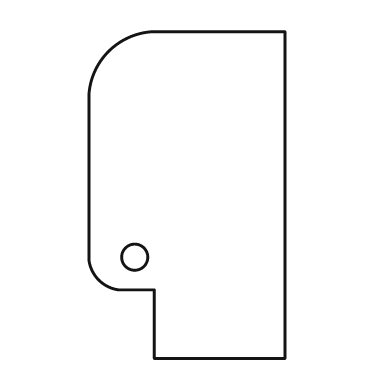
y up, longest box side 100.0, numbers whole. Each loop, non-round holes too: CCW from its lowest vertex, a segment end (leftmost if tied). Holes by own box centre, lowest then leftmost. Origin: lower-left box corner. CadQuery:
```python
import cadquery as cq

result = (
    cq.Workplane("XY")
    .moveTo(20.0, 0.0)
    .lineTo(60.0, 0.0)
    .lineTo(60.0, 100.0)
    .lineTo(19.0, 100.0)
    .threePointArc((6.0, 94.0), (0.0, 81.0))
    .lineTo(0.0, 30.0)
    .threePointArc((3.0, 24.0), (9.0, 21.0))
    .lineTo(20.0, 21.0)
    .close()
    .moveTo(14.0, 31.0)
    .circle(4.0)
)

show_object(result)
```